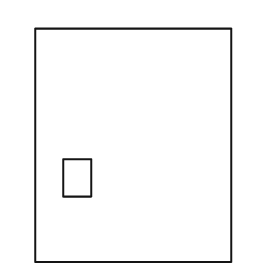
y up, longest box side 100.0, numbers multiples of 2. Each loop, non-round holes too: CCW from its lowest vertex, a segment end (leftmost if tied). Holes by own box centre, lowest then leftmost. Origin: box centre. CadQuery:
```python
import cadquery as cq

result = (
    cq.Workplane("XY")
    .moveTo(-42.0, -50.0)
    .lineTo(42.0, -50.0)
    .lineTo(42.0, 50.0)
    .lineTo(-42.0, 50.0)
    .close()
    .moveTo(-30.0, -22.0)
    .lineTo(-18.0, -22.0)
    .lineTo(-18.0, -6.0)
    .lineTo(-30.0, -6.0)
    .close()
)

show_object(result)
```